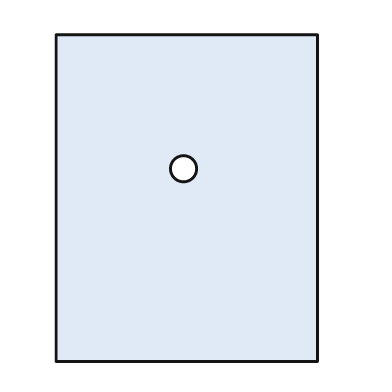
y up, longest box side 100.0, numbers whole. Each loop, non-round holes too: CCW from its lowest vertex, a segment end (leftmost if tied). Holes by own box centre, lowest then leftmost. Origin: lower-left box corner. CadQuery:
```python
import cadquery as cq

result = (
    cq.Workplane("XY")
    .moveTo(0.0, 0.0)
    .lineTo(80.0, 0.0)
    .lineTo(80.0, 100.0)
    .lineTo(0.0, 100.0)
    .close()
    .moveTo(39.0, 59.0)
    .circle(4.0)
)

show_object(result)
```